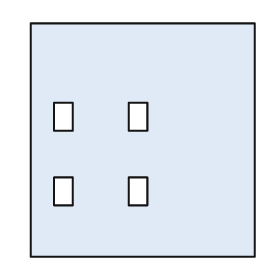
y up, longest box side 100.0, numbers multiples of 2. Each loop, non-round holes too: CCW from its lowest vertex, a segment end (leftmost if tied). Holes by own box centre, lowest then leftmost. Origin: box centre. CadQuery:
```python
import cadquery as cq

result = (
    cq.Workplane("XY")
    .moveTo(-48.0, -50.0)
    .lineTo(48.0, -50.0)
    .lineTo(48.0, 50.0)
    .lineTo(-48.0, 50.0)
    .close()
    .moveTo(-38.0, -28.0)
    .lineTo(-30.0, -28.0)
    .lineTo(-30.0, -16.0)
    .lineTo(-38.0, -16.0)
    .close()
    .moveTo(-6.0, -28.0)
    .lineTo(2.0, -28.0)
    .lineTo(2.0, -16.0)
    .lineTo(-6.0, -16.0)
    .close()
    .moveTo(-38.0, 4.0)
    .lineTo(-30.0, 4.0)
    .lineTo(-30.0, 16.0)
    .lineTo(-38.0, 16.0)
    .close()
    .moveTo(-6.0, 4.0)
    .lineTo(2.0, 4.0)
    .lineTo(2.0, 16.0)
    .lineTo(-6.0, 16.0)
    .close()
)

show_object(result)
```